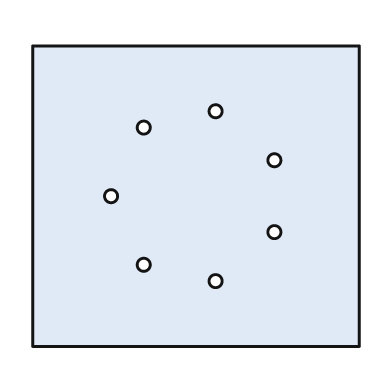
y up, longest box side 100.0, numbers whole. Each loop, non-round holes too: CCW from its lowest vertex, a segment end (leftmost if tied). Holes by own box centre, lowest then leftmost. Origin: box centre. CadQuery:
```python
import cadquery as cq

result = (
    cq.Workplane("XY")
    .moveTo(-50.0, -46.0)
    .lineTo(50.0, -46.0)
    .lineTo(50.0, 46.0)
    .lineTo(-50.0, 46.0)
    .close()
    .moveTo(6.0, -26.0)
    .circle(2.0)
    .moveTo(-16.0, -21.0)
    .circle(2.0)
    .moveTo(24.0, -11.0)
    .circle(2.0)
    .moveTo(-26.0, 0.0)
    .circle(2.0)
    .moveTo(24.0, 11.0)
    .circle(2.0)
    .moveTo(-16.0, 21.0)
    .circle(2.0)
    .moveTo(6.0, 26.0)
    .circle(2.0)
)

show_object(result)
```